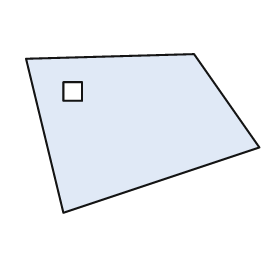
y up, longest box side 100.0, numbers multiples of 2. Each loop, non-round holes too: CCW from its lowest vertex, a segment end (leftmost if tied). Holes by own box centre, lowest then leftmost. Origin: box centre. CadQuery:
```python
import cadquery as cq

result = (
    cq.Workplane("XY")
    .moveTo(-34.0, -34.0)
    .lineTo(50.0, -6.0)
    .lineTo(22.0, 34.0)
    .lineTo(-50.0, 32.0)
    .close()
    .moveTo(-34.0, 14.0)
    .lineTo(-26.0, 14.0)
    .lineTo(-26.0, 22.0)
    .lineTo(-34.0, 22.0)
    .close()
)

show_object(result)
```